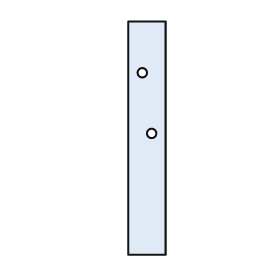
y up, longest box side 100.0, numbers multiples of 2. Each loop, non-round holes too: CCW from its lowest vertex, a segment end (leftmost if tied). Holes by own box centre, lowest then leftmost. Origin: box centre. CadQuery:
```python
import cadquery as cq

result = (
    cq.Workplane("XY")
    .moveTo(-8.0, -50.0)
    .lineTo(8.0, -50.0)
    .lineTo(8.0, 50.0)
    .lineTo(-8.0, 50.0)
    .close()
    .moveTo(2.0, 2.0)
    .circle(2.0)
    .moveTo(-2.0, 28.0)
    .circle(2.0)
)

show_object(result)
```